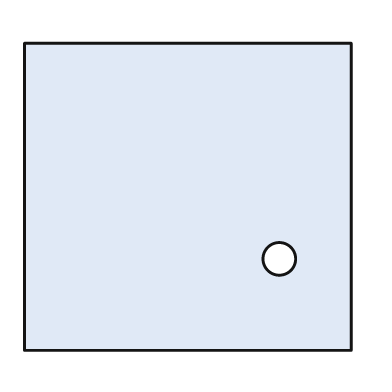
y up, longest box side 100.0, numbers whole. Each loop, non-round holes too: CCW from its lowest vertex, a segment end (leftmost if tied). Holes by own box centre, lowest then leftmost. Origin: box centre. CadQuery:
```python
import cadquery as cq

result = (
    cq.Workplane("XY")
    .moveTo(-50.0, -47.0)
    .lineTo(50.0, -47.0)
    .lineTo(50.0, 47.0)
    .lineTo(-50.0, 47.0)
    .close()
    .moveTo(28.0, -19.0)
    .circle(5.0)
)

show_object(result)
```